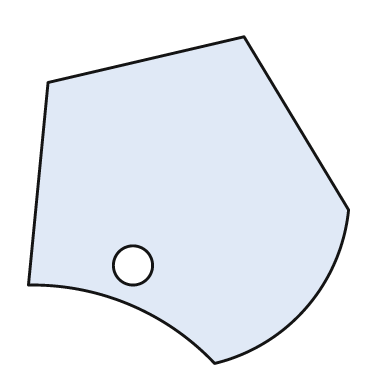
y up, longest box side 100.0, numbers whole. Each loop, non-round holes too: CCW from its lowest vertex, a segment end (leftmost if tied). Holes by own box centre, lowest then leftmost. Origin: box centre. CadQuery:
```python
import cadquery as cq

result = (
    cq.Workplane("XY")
    .moveTo(8.0, -50.0)
    .threePointArc((36.0, -33.0), (49.0, -3.0))
    .lineTo(17.0, 50.0)
    .lineTo(-43.0, 36.0)
    .lineTo(-49.0, -26.0)
    .threePointArc((-18.0, -32.0), (8.0, -50.0))
    .close()
    .moveTo(-17.0, -20.0)
    .circle(6.0)
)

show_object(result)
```